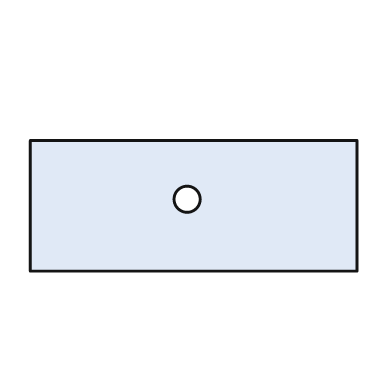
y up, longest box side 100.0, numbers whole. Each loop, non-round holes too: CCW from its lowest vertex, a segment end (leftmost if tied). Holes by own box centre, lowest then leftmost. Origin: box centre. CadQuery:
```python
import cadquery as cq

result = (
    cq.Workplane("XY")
    .moveTo(-50.0, -20.0)
    .lineTo(50.0, -20.0)
    .lineTo(50.0, 20.0)
    .lineTo(-50.0, 20.0)
    .close()
    .moveTo(-2.0, 2.0)
    .circle(4.0)
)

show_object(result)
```